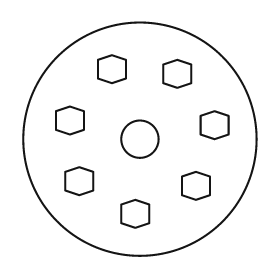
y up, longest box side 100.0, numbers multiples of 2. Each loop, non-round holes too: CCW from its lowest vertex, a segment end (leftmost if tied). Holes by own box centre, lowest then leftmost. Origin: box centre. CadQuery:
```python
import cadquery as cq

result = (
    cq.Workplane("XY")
    .moveTo(0.0, 0.0)
    .circle(50.0)
    .moveTo(-2.0, -38.0)
    .lineTo(4.0, -36.0)
    .lineTo(4.0, -28.0)
    .lineTo(-2.0, -26.0)
    .lineTo(-8.0, -28.0)
    .lineTo(-8.0, -36.0)
    .close()
    .moveTo(24.0, -26.0)
    .lineTo(30.0, -24.0)
    .lineTo(30.0, -16.0)
    .lineTo(24.0, -14.0)
    .lineTo(18.0, -16.0)
    .lineTo(18.0, -24.0)
    .close()
    .moveTo(-26.0, -24.0)
    .lineTo(-20.0, -22.0)
    .lineTo(-20.0, -14.0)
    .lineTo(-26.0, -12.0)
    .lineTo(-32.0, -14.0)
    .lineTo(-32.0, -22.0)
    .close()
    .moveTo(0.0, 0.0)
    .circle(8.0)
    .moveTo(32.0, 0.0)
    .lineTo(38.0, 2.0)
    .lineTo(38.0, 10.0)
    .lineTo(32.0, 12.0)
    .lineTo(26.0, 10.0)
    .lineTo(26.0, 2.0)
    .close()
    .moveTo(-30.0, 2.0)
    .lineTo(-24.0, 4.0)
    .lineTo(-24.0, 12.0)
    .lineTo(-30.0, 14.0)
    .lineTo(-36.0, 12.0)
    .lineTo(-36.0, 4.0)
    .close()
    .moveTo(16.0, 22.0)
    .lineTo(22.0, 24.0)
    .lineTo(22.0, 32.0)
    .lineTo(16.0, 34.0)
    .lineTo(10.0, 32.0)
    .lineTo(10.0, 24.0)
    .close()
    .moveTo(-12.0, 24.0)
    .lineTo(-6.0, 26.0)
    .lineTo(-6.0, 34.0)
    .lineTo(-12.0, 36.0)
    .lineTo(-18.0, 34.0)
    .lineTo(-18.0, 26.0)
    .close()
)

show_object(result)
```